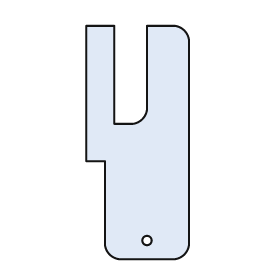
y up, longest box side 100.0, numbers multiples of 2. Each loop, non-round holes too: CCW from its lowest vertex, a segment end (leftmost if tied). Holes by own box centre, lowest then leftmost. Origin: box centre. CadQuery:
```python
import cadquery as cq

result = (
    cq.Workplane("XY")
    .moveTo(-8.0, -50.0)
    .lineTo(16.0, -50.0)
    .threePointArc((20.0, -48.0), (22.0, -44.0))
    .lineTo(22.0, 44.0)
    .threePointArc((20.0, 48.0), (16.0, 50.0))
    .lineTo(4.0, 50.0)
    .lineTo(4.0, 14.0)
    .threePointArc((2.0, 10.0), (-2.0, 8.0))
    .lineTo(-10.0, 8.0)
    .lineTo(-10.0, 50.0)
    .lineTo(-22.0, 50.0)
    .lineTo(-22.0, -8.0)
    .lineTo(-14.0, -8.0)
    .lineTo(-14.0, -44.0)
    .threePointArc((-12.0, -48.0), (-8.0, -50.0))
    .close()
    .moveTo(4.0, -42.0)
    .circle(2.0)
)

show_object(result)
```